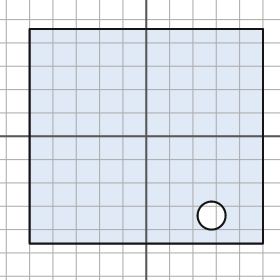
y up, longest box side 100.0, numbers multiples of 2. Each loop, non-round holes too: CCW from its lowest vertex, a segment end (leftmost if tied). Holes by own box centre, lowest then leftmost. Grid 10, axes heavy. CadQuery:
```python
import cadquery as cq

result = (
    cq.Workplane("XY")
    .moveTo(-50.0, -46.0)
    .lineTo(50.0, -46.0)
    .lineTo(50.0, 46.0)
    .lineTo(-50.0, 46.0)
    .close()
    .moveTo(28.0, -34.0)
    .circle(6.0)
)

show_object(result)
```